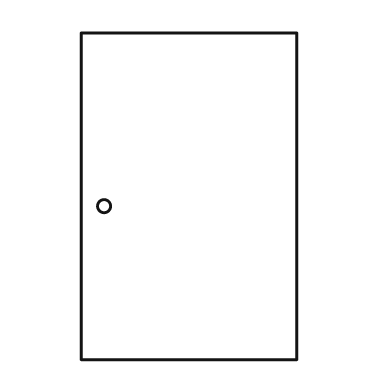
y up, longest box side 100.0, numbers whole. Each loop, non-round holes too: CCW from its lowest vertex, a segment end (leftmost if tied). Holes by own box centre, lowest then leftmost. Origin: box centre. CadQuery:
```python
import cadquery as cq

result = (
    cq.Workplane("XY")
    .moveTo(-33.0, -50.0)
    .lineTo(33.0, -50.0)
    .lineTo(33.0, 50.0)
    .lineTo(-33.0, 50.0)
    .close()
    .moveTo(-26.0, -3.0)
    .circle(2.0)
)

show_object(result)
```